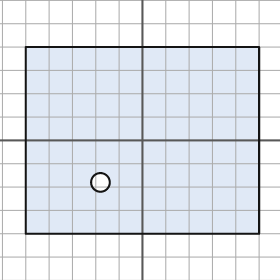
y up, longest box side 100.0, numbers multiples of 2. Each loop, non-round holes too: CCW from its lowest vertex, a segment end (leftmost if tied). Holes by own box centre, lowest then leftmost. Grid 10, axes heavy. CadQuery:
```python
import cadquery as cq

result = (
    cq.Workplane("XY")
    .moveTo(-50.0, -40.0)
    .lineTo(50.0, -40.0)
    .lineTo(50.0, 40.0)
    .lineTo(-50.0, 40.0)
    .close()
    .moveTo(-18.0, -18.0)
    .circle(4.0)
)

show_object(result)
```